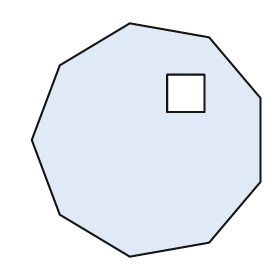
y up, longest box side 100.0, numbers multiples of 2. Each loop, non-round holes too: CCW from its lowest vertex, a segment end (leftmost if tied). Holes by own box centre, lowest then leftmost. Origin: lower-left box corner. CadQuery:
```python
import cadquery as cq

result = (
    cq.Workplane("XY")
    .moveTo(42.0, 0.0)
    .lineTo(76.0, 6.0)
    .lineTo(98.0, 32.0)
    .lineTo(98.0, 68.0)
    .lineTo(76.0, 94.0)
    .lineTo(42.0, 100.0)
    .lineTo(12.0, 82.0)
    .lineTo(0.0, 50.0)
    .lineTo(12.0, 18.0)
    .close()
    .moveTo(58.0, 62.0)
    .lineTo(74.0, 62.0)
    .lineTo(74.0, 78.0)
    .lineTo(58.0, 78.0)
    .close()
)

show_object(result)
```